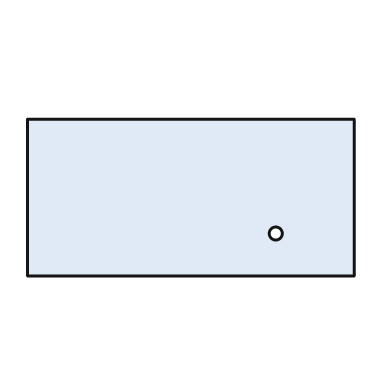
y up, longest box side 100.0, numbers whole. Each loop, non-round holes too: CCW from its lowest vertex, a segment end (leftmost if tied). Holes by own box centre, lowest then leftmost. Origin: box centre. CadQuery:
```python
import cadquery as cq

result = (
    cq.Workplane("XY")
    .moveTo(-50.0, -24.0)
    .lineTo(50.0, -24.0)
    .lineTo(50.0, 24.0)
    .lineTo(-50.0, 24.0)
    .close()
    .moveTo(26.0, -11.0)
    .circle(2.0)
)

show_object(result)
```